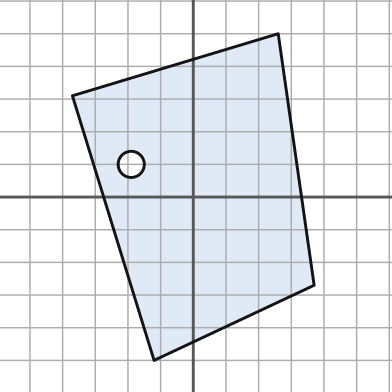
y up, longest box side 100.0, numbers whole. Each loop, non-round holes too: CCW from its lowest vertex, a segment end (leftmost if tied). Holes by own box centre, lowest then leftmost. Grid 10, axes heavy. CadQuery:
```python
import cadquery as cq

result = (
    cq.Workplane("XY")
    .moveTo(-12.0, -50.0)
    .lineTo(37.0, -27.0)
    .lineTo(26.0, 50.0)
    .lineTo(-37.0, 31.0)
    .close()
    .moveTo(-19.0, 10.0)
    .circle(4.0)
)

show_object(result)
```